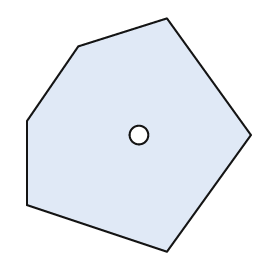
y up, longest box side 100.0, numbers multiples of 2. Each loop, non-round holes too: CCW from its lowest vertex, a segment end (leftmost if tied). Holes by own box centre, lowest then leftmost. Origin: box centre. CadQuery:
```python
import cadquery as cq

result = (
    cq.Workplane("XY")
    .moveTo(12.0, -50.0)
    .lineTo(48.0, 0.0)
    .lineTo(12.0, 50.0)
    .lineTo(-26.0, 38.0)
    .lineTo(-48.0, 6.0)
    .lineTo(-48.0, -30.0)
    .close()
    .moveTo(0.0, 0.0)
    .circle(4.0)
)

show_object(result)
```